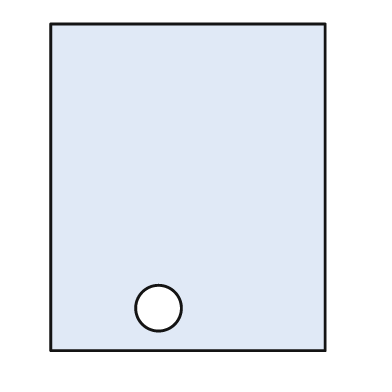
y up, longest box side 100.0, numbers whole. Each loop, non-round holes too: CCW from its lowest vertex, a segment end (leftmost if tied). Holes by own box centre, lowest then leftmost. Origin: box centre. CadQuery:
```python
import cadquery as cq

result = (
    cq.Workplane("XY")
    .moveTo(-42.0, -50.0)
    .lineTo(42.0, -50.0)
    .lineTo(42.0, 50.0)
    .lineTo(-42.0, 50.0)
    .close()
    .moveTo(-9.0, -37.0)
    .circle(7.0)
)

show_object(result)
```